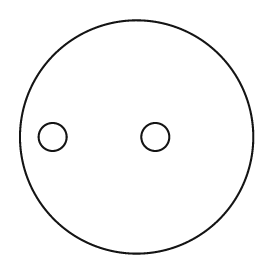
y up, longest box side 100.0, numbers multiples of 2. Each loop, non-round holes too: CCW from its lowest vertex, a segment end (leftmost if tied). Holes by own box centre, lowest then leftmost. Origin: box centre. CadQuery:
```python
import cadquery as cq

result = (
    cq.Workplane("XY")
    .moveTo(0.0, 0.0)
    .circle(50.0)
    .moveTo(-36.0, 0.0)
    .circle(6.0)
    .moveTo(8.0, 0.0)
    .circle(6.0)
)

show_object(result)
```